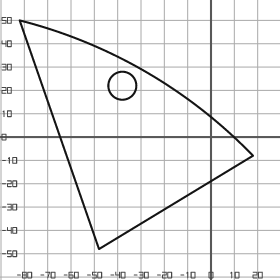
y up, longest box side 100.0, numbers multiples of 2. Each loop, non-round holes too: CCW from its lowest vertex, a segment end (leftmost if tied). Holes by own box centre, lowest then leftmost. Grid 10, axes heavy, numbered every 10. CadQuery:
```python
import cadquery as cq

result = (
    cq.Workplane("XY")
    .moveTo(-48.0, -48.0)
    .lineTo(18.0, -8.0)
    .threePointArc((-28.0, 28.0), (-82.0, 50.0))
    .close()
    .moveTo(-38.0, 22.0)
    .circle(6.0)
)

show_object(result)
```